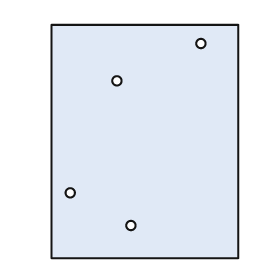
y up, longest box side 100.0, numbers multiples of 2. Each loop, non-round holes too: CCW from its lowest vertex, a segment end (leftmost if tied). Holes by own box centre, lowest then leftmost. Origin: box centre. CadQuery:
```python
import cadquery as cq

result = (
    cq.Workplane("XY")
    .moveTo(-40.0, -50.0)
    .lineTo(40.0, -50.0)
    .lineTo(40.0, 50.0)
    .lineTo(-40.0, 50.0)
    .close()
    .moveTo(-6.0, -36.0)
    .circle(2.0)
    .moveTo(-32.0, -22.0)
    .circle(2.0)
    .moveTo(-12.0, 26.0)
    .circle(2.0)
    .moveTo(24.0, 42.0)
    .circle(2.0)
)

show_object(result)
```